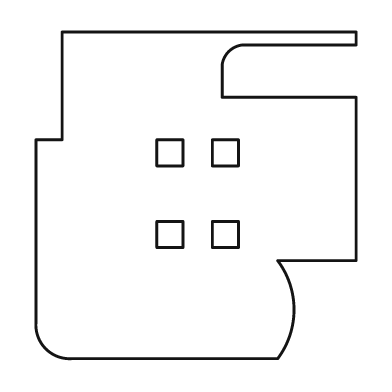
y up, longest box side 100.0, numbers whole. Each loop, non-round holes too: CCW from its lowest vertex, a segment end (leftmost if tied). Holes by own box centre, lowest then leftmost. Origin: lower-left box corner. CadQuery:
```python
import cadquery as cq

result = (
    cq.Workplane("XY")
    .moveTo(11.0, 0.0)
    .lineTo(74.0, 0.0)
    .threePointArc((79.0, 15.0), (74.0, 30.0))
    .lineTo(98.0, 30.0)
    .lineTo(98.0, 80.0)
    .lineTo(57.0, 80.0)
    .lineTo(57.0, 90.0)
    .threePointArc((59.0, 94.0), (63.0, 96.0))
    .lineTo(98.0, 96.0)
    .lineTo(98.0, 100.0)
    .lineTo(8.0, 100.0)
    .lineTo(8.0, 67.0)
    .lineTo(0.0, 67.0)
    .lineTo(0.0, 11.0)
    .threePointArc((3.0, 3.0), (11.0, 0.0))
    .close()
    .moveTo(37.0, 34.0)
    .lineTo(45.0, 34.0)
    .lineTo(45.0, 42.0)
    .lineTo(37.0, 42.0)
    .close()
    .moveTo(54.0, 34.0)
    .lineTo(62.0, 34.0)
    .lineTo(62.0, 42.0)
    .lineTo(54.0, 42.0)
    .close()
    .moveTo(37.0, 59.0)
    .lineTo(45.0, 59.0)
    .lineTo(45.0, 67.0)
    .lineTo(37.0, 67.0)
    .close()
    .moveTo(54.0, 59.0)
    .lineTo(62.0, 59.0)
    .lineTo(62.0, 67.0)
    .lineTo(54.0, 67.0)
    .close()
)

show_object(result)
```